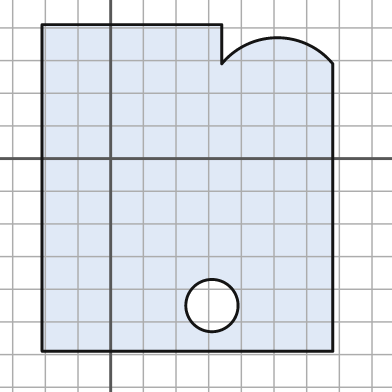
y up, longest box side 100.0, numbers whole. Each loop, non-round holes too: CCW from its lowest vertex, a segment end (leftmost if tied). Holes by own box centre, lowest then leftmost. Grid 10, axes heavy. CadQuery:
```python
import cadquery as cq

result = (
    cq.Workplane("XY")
    .moveTo(-21.0, -59.0)
    .lineTo(68.0, -59.0)
    .lineTo(68.0, 29.0)
    .threePointArc((51.0, 37.0), (34.0, 29.0))
    .lineTo(34.0, 41.0)
    .lineTo(-21.0, 41.0)
    .close()
    .moveTo(31.0, -45.0)
    .circle(8.0)
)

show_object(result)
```